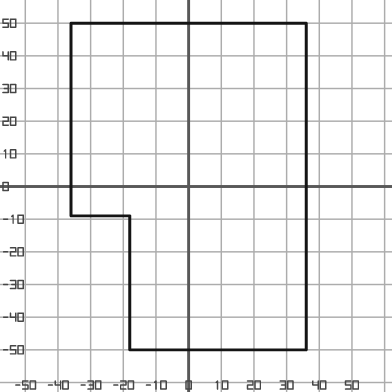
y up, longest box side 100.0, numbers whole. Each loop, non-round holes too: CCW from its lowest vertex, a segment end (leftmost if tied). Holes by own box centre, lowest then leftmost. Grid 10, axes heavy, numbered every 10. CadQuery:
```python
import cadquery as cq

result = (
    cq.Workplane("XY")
    .moveTo(-18.0, -50.0)
    .lineTo(36.0, -50.0)
    .lineTo(36.0, 50.0)
    .lineTo(-36.0, 50.0)
    .lineTo(-36.0, -9.0)
    .lineTo(-18.0, -9.0)
    .close()
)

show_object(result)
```